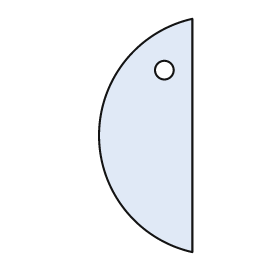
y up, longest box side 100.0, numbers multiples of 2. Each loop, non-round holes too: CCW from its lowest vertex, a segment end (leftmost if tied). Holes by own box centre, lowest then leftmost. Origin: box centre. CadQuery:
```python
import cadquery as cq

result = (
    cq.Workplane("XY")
    .moveTo(20.0, -50.0)
    .lineTo(20.0, 50.0)
    .threePointArc((-20.0, 0.0), (20.0, -50.0))
    .close()
    .moveTo(8.0, 28.0)
    .circle(4.0)
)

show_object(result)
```